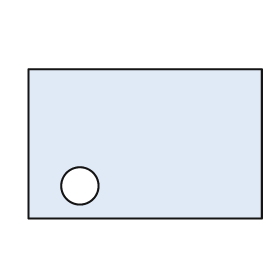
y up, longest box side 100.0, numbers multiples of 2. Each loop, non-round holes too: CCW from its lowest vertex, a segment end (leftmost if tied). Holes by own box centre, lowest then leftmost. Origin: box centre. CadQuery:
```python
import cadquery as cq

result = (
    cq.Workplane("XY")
    .moveTo(-50.0, -32.0)
    .lineTo(50.0, -32.0)
    .lineTo(50.0, 32.0)
    .lineTo(-50.0, 32.0)
    .close()
    .moveTo(-28.0, -18.0)
    .circle(8.0)
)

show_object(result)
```